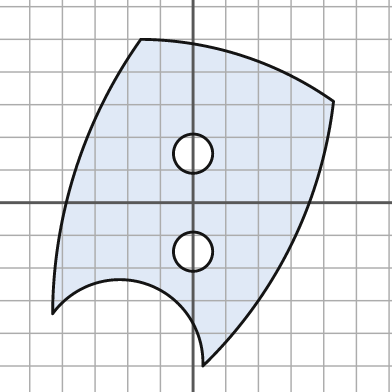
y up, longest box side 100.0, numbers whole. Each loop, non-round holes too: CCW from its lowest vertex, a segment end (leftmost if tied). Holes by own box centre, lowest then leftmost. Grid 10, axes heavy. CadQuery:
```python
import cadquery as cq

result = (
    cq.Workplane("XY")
    .moveTo(3.0, -50.0)
    .threePointArc((30.0, -13.0), (43.0, 31.0))
    .threePointArc((15.0, 45.0), (-16.0, 50.0))
    .threePointArc((-36.0, 10.0), (-43.0, -34.0))
    .threePointArc((-14.0, -25.0), (3.0, -50.0))
    .close()
    .moveTo(0.0, -15.0)
    .circle(6.0)
    .moveTo(0.0, 15.0)
    .circle(6.0)
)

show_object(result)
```